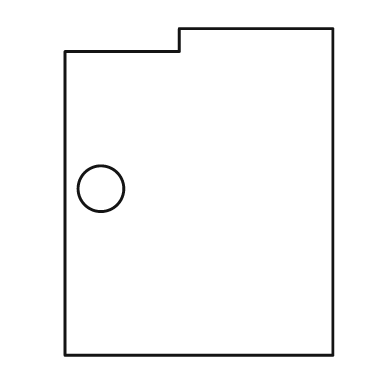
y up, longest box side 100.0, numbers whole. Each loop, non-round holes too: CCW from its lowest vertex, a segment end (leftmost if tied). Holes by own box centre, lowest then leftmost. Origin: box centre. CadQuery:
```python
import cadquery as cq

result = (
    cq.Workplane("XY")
    .moveTo(-41.0, -50.0)
    .lineTo(41.0, -50.0)
    .lineTo(41.0, 50.0)
    .lineTo(-6.0, 50.0)
    .lineTo(-6.0, 43.0)
    .lineTo(-41.0, 43.0)
    .close()
    .moveTo(-30.0, 1.0)
    .circle(7.0)
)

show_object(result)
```